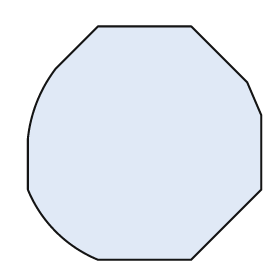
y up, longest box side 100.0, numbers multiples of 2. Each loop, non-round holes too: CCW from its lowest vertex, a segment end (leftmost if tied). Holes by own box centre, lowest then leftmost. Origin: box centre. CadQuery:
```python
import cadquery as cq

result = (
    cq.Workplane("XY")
    .moveTo(-20.0, -50.0)
    .lineTo(20.0, -50.0)
    .lineTo(50.0, -20.0)
    .lineTo(50.0, 12.0)
    .lineTo(44.0, 26.0)
    .lineTo(20.0, 50.0)
    .lineTo(-20.0, 50.0)
    .lineTo(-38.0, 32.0)
    .threePointArc((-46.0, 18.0), (-50.0, 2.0))
    .lineTo(-50.0, -20.0)
    .threePointArc((-38.0, -38.0), (-20.0, -50.0))
    .close()
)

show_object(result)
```